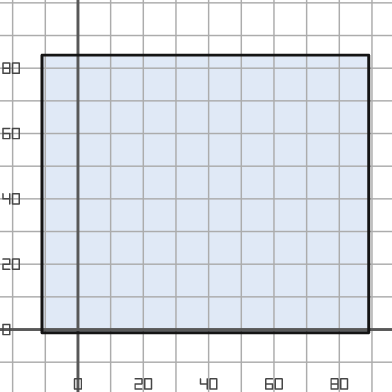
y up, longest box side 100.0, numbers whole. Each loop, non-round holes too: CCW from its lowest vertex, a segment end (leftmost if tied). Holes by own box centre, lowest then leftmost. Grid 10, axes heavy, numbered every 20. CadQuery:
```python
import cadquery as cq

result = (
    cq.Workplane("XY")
    .moveTo(-11.0, -1.0)
    .lineTo(89.0, -1.0)
    .lineTo(89.0, 84.0)
    .lineTo(-11.0, 84.0)
    .close()
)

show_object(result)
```